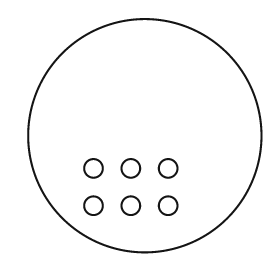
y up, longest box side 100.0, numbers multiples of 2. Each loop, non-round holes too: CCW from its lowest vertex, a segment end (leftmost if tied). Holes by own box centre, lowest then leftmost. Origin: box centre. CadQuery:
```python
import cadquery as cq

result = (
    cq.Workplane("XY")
    .moveTo(0.0, 0.0)
    .circle(50.0)
    .moveTo(-22.0, -30.0)
    .circle(4.0)
    .moveTo(-6.0, -30.0)
    .circle(4.0)
    .moveTo(10.0, -30.0)
    .circle(4.0)
    .moveTo(-22.0, -14.0)
    .circle(4.0)
    .moveTo(-6.0, -14.0)
    .circle(4.0)
    .moveTo(10.0, -14.0)
    .circle(4.0)
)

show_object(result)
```